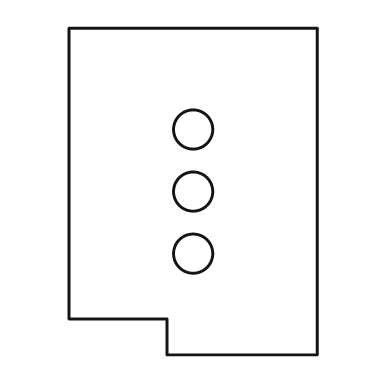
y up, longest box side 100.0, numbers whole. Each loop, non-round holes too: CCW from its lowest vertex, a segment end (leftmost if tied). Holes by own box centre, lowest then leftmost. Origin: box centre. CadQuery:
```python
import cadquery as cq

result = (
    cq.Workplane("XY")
    .moveTo(-8.0, -50.0)
    .lineTo(38.0, -50.0)
    .lineTo(38.0, 50.0)
    .lineTo(-38.0, 50.0)
    .lineTo(-38.0, -39.0)
    .lineTo(-8.0, -39.0)
    .close()
    .moveTo(0.0, -19.0)
    .circle(6.0)
    .moveTo(0.0, 0.0)
    .circle(6.0)
    .moveTo(0.0, 19.0)
    .circle(6.0)
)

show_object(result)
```